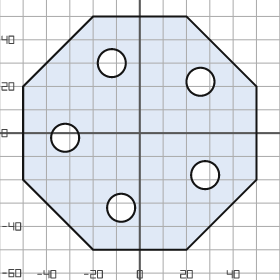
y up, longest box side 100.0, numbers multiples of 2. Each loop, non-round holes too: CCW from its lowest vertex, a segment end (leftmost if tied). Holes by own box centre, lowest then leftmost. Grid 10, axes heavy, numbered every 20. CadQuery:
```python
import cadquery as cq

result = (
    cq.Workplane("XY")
    .moveTo(-20.0, -50.0)
    .lineTo(20.0, -50.0)
    .lineTo(50.0, -20.0)
    .lineTo(50.0, 20.0)
    .lineTo(20.0, 50.0)
    .lineTo(-20.0, 50.0)
    .lineTo(-50.0, 20.0)
    .lineTo(-50.0, -20.0)
    .close()
    .moveTo(-8.0, -32.0)
    .circle(6.0)
    .moveTo(28.0, -18.0)
    .circle(6.0)
    .moveTo(-32.0, -2.0)
    .circle(6.0)
    .moveTo(26.0, 22.0)
    .circle(6.0)
    .moveTo(-12.0, 30.0)
    .circle(6.0)
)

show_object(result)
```